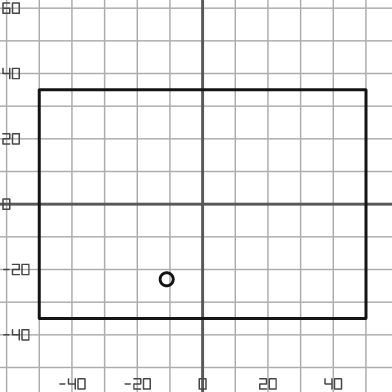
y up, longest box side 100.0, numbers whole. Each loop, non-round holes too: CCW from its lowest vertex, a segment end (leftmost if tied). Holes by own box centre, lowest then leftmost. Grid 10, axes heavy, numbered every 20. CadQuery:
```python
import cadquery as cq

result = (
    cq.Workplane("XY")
    .moveTo(-50.0, -35.0)
    .lineTo(50.0, -35.0)
    .lineTo(50.0, 35.0)
    .lineTo(-50.0, 35.0)
    .close()
    .moveTo(-11.0, -23.0)
    .circle(2.0)
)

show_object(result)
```